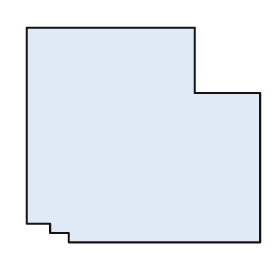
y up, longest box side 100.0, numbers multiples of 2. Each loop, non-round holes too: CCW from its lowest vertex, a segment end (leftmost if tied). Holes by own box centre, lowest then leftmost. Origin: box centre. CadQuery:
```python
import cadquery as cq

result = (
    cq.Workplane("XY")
    .moveTo(-32.0, -46.0)
    .lineTo(50.0, -46.0)
    .lineTo(50.0, 18.0)
    .lineTo(22.0, 18.0)
    .lineTo(22.0, 46.0)
    .lineTo(-50.0, 46.0)
    .lineTo(-50.0, -38.0)
    .lineTo(-40.0, -38.0)
    .lineTo(-40.0, -42.0)
    .lineTo(-32.0, -42.0)
    .close()
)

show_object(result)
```